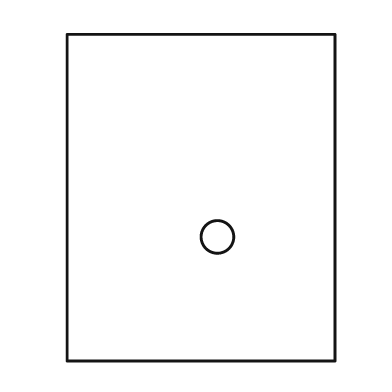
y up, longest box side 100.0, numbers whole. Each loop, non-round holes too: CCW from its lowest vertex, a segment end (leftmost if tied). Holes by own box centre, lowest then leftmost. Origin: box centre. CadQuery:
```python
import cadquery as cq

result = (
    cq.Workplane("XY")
    .moveTo(-41.0, -50.0)
    .lineTo(41.0, -50.0)
    .lineTo(41.0, 50.0)
    .lineTo(-41.0, 50.0)
    .close()
    .moveTo(5.0, -12.0)
    .circle(5.0)
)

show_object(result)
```